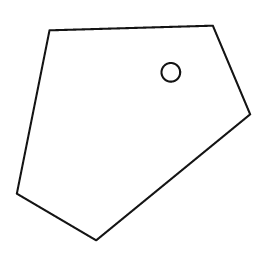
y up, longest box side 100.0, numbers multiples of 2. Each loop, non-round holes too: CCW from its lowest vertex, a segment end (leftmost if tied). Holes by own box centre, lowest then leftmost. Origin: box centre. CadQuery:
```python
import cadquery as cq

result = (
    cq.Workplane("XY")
    .moveTo(-16.0, -46.0)
    .lineTo(50.0, 8.0)
    .lineTo(34.0, 46.0)
    .lineTo(-36.0, 44.0)
    .lineTo(-50.0, -26.0)
    .close()
    .moveTo(16.0, 26.0)
    .circle(4.0)
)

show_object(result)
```